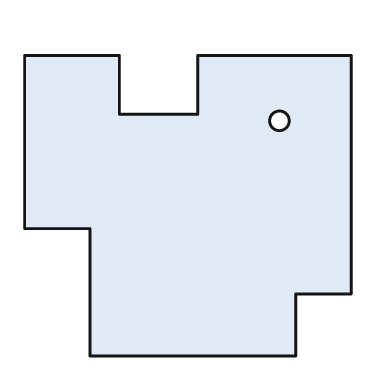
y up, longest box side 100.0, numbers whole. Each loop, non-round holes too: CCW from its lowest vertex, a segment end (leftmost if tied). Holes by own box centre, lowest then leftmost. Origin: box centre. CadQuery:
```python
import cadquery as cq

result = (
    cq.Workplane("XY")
    .moveTo(-30.0, -46.0)
    .lineTo(33.0, -46.0)
    .lineTo(33.0, -27.0)
    .lineTo(50.0, -27.0)
    .lineTo(50.0, 46.0)
    .lineTo(3.0, 46.0)
    .lineTo(3.0, 28.0)
    .lineTo(-21.0, 28.0)
    .lineTo(-21.0, 46.0)
    .lineTo(-50.0, 46.0)
    .lineTo(-50.0, -7.0)
    .lineTo(-30.0, -7.0)
    .close()
    .moveTo(28.0, 26.0)
    .circle(3.0)
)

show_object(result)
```